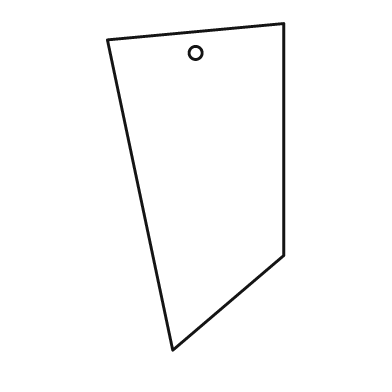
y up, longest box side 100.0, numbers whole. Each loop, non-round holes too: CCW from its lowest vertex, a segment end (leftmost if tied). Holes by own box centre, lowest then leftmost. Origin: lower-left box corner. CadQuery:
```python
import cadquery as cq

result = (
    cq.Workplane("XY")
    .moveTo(20.0, 0.0)
    .lineTo(54.0, 29.0)
    .lineTo(54.0, 100.0)
    .lineTo(0.0, 95.0)
    .close()
    .moveTo(27.0, 91.0)
    .circle(2.0)
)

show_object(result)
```